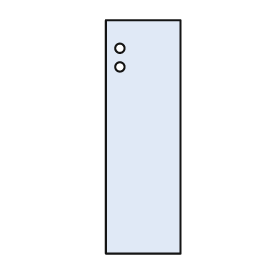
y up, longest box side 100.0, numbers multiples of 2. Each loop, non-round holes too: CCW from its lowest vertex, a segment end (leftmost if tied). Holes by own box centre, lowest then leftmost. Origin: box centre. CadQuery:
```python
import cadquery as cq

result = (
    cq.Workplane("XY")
    .moveTo(-16.0, -50.0)
    .lineTo(16.0, -50.0)
    .lineTo(16.0, 50.0)
    .lineTo(-16.0, 50.0)
    .close()
    .moveTo(-10.0, 30.0)
    .circle(2.0)
    .moveTo(-10.0, 38.0)
    .circle(2.0)
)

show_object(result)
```